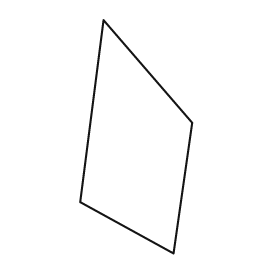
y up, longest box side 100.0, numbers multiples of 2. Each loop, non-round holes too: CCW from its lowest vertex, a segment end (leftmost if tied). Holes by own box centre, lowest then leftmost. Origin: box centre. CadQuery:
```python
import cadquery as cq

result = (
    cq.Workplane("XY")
    .moveTo(16.0, -50.0)
    .lineTo(24.0, 6.0)
    .lineTo(-14.0, 50.0)
    .lineTo(-24.0, -28.0)
    .close()
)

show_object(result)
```